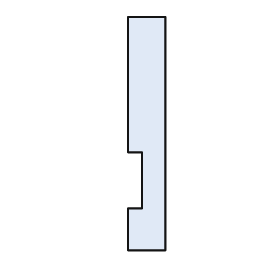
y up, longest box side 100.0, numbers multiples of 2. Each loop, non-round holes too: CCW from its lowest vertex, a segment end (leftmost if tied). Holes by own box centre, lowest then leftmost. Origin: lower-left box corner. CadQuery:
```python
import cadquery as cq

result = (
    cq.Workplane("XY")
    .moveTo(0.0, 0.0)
    .lineTo(16.0, 0.0)
    .lineTo(16.0, 100.0)
    .lineTo(0.0, 100.0)
    .lineTo(0.0, 42.0)
    .lineTo(6.0, 42.0)
    .lineTo(6.0, 18.0)
    .lineTo(0.0, 18.0)
    .close()
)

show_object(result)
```